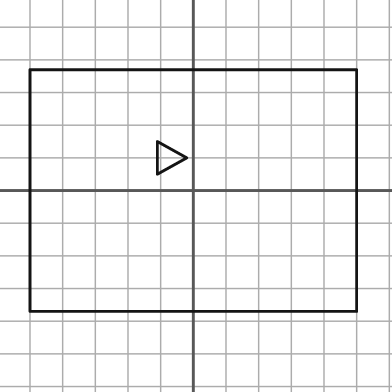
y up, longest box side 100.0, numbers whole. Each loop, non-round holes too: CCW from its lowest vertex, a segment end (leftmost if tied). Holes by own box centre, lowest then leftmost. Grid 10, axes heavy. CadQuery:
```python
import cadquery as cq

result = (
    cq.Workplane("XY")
    .moveTo(-50.0, -37.0)
    .lineTo(50.0, -37.0)
    .lineTo(50.0, 37.0)
    .lineTo(-50.0, 37.0)
    .close()
    .moveTo(-11.0, 5.0)
    .lineTo(-2.0, 10.0)
    .lineTo(-11.0, 15.0)
    .close()
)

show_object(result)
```